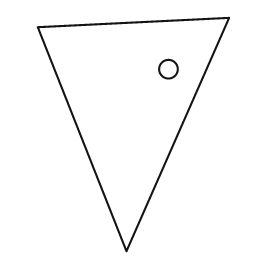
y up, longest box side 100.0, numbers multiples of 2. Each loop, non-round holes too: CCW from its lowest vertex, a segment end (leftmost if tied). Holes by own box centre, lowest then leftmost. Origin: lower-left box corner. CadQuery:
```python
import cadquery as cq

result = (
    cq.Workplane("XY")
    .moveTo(38.0, 0.0)
    .lineTo(82.0, 100.0)
    .lineTo(0.0, 96.0)
    .close()
    .moveTo(56.0, 78.0)
    .circle(4.0)
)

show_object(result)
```